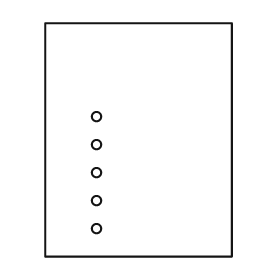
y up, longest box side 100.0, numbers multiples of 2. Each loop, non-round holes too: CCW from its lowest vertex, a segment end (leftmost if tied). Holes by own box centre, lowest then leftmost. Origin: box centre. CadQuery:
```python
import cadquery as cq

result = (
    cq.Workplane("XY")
    .moveTo(-40.0, -50.0)
    .lineTo(40.0, -50.0)
    .lineTo(40.0, 50.0)
    .lineTo(-40.0, 50.0)
    .close()
    .moveTo(-18.0, -38.0)
    .circle(2.0)
    .moveTo(-18.0, -26.0)
    .circle(2.0)
    .moveTo(-18.0, -14.0)
    .circle(2.0)
    .moveTo(-18.0, -2.0)
    .circle(2.0)
    .moveTo(-18.0, 10.0)
    .circle(2.0)
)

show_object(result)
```